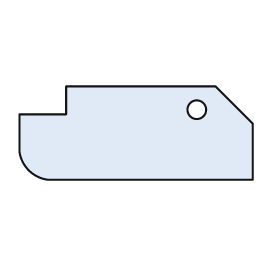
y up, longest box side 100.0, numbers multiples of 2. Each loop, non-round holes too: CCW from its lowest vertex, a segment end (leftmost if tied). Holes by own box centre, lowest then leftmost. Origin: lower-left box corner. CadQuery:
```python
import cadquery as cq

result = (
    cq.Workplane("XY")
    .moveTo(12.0, 0.0)
    .lineTo(100.0, 0.0)
    .lineTo(100.0, 24.0)
    .lineTo(84.0, 40.0)
    .lineTo(20.0, 40.0)
    .lineTo(20.0, 28.0)
    .lineTo(0.0, 28.0)
    .lineTo(0.0, 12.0)
    .threePointArc((4.0, 4.0), (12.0, 0.0))
    .close()
    .moveTo(76.0, 30.0)
    .circle(4.0)
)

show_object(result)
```